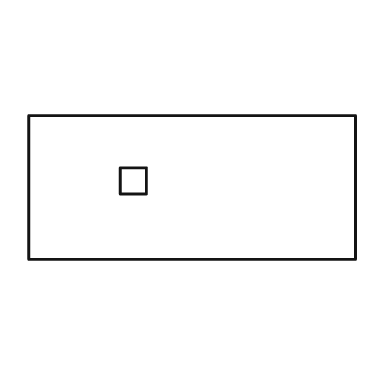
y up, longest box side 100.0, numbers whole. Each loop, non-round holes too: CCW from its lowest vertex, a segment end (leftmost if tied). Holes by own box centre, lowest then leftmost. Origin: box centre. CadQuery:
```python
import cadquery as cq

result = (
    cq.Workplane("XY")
    .moveTo(-50.0, -22.0)
    .lineTo(50.0, -22.0)
    .lineTo(50.0, 22.0)
    .lineTo(-50.0, 22.0)
    .close()
    .moveTo(-22.0, -2.0)
    .lineTo(-14.0, -2.0)
    .lineTo(-14.0, 6.0)
    .lineTo(-22.0, 6.0)
    .close()
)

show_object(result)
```